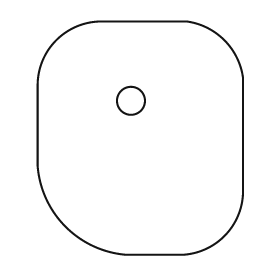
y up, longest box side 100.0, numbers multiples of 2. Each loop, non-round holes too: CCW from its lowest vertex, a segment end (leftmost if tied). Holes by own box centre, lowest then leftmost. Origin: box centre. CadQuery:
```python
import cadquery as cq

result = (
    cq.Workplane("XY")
    .moveTo(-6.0, -50.0)
    .lineTo(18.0, -50.0)
    .threePointArc((36.0, -42.0), (44.0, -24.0))
    .lineTo(44.0, 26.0)
    .threePointArc((36.0, 42.0), (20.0, 50.0))
    .lineTo(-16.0, 50.0)
    .threePointArc((-36.0, 42.0), (-44.0, 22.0))
    .lineTo(-44.0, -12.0)
    .threePointArc((-32.0, -38.0), (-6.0, -50.0))
    .close()
    .moveTo(-4.0, 16.0)
    .circle(6.0)
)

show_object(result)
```